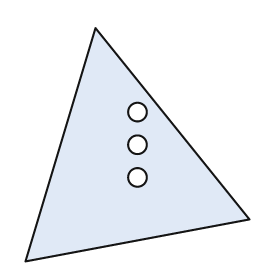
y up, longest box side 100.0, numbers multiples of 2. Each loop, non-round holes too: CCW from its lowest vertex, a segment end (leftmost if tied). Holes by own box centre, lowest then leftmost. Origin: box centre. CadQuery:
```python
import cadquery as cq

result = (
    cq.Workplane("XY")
    .moveTo(-48.0, -50.0)
    .lineTo(48.0, -32.0)
    .lineTo(-18.0, 50.0)
    .close()
    .moveTo(0.0, -14.0)
    .circle(4.0)
    .moveTo(0.0, 0.0)
    .circle(4.0)
    .moveTo(0.0, 14.0)
    .circle(4.0)
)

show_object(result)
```